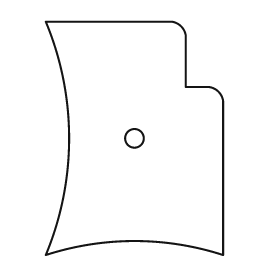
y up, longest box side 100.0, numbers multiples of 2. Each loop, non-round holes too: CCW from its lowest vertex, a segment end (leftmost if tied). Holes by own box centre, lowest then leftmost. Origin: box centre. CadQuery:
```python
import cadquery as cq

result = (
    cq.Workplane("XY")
    .moveTo(-38.0, -50.0)
    .threePointArc((0.0, -44.0), (38.0, -50.0))
    .lineTo(38.0, 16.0)
    .threePointArc((36.0, 20.0), (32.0, 22.0))
    .lineTo(22.0, 22.0)
    .lineTo(22.0, 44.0)
    .threePointArc((20.0, 48.0), (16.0, 50.0))
    .lineTo(-38.0, 50.0)
    .threePointArc((-28.0, 0.0), (-38.0, -50.0))
    .close()
    .moveTo(0.0, 0.0)
    .circle(4.0)
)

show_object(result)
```